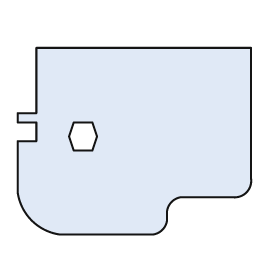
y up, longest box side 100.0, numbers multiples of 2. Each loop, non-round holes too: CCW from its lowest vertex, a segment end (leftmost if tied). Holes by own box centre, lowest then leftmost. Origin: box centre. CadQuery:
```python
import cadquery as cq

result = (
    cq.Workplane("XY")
    .moveTo(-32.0, -40.0)
    .lineTo(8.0, -40.0)
    .threePointArc((12.0, -38.0), (14.0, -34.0))
    .lineTo(14.0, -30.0)
    .threePointArc((16.0, -26.0), (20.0, -24.0))
    .lineTo(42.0, -24.0)
    .threePointArc((48.0, -22.0), (50.0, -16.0))
    .lineTo(50.0, 40.0)
    .lineTo(-42.0, 40.0)
    .lineTo(-42.0, 12.0)
    .lineTo(-50.0, 12.0)
    .lineTo(-50.0, 8.0)
    .lineTo(-42.0, 8.0)
    .lineTo(-42.0, 0.0)
    .lineTo(-50.0, 0.0)
    .lineTo(-50.0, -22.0)
    .threePointArc((-44.0, -34.0), (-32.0, -40.0))
    .close()
    .moveTo(-26.0, -4.0)
    .lineTo(-18.0, -4.0)
    .lineTo(-16.0, 2.0)
    .lineTo(-18.0, 8.0)
    .lineTo(-26.0, 8.0)
    .lineTo(-28.0, 2.0)
    .close()
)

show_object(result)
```